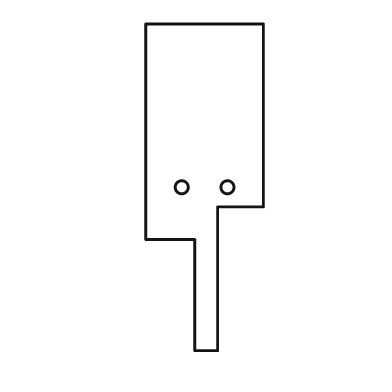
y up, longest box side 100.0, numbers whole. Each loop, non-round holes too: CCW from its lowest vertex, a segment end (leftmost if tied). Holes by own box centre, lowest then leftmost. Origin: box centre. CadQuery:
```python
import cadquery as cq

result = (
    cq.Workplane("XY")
    .moveTo(-3.0, -50.0)
    .lineTo(4.0, -50.0)
    .lineTo(4.0, -6.0)
    .lineTo(18.0, -6.0)
    .lineTo(18.0, 50.0)
    .lineTo(-18.0, 50.0)
    .lineTo(-18.0, -16.0)
    .lineTo(-3.0, -16.0)
    .close()
    .moveTo(-7.0, 0.0)
    .circle(2.0)
    .moveTo(7.0, 0.0)
    .circle(2.0)
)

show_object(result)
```